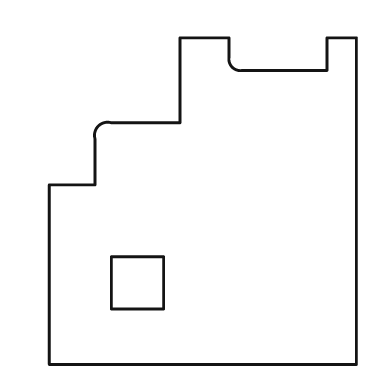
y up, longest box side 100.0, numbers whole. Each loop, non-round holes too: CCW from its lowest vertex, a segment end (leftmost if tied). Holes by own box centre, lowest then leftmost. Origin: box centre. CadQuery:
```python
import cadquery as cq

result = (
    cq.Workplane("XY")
    .moveTo(-47.0, -50.0)
    .lineTo(47.0, -50.0)
    .lineTo(47.0, 50.0)
    .lineTo(38.0, 50.0)
    .lineTo(38.0, 40.0)
    .lineTo(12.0, 40.0)
    .threePointArc((9.0, 41.0), (8.0, 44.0))
    .lineTo(8.0, 50.0)
    .lineTo(-7.0, 50.0)
    .lineTo(-7.0, 24.0)
    .lineTo(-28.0, 24.0)
    .threePointArc((-32.0, 23.0), (-33.0, 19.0))
    .lineTo(-33.0, 5.0)
    .lineTo(-47.0, 5.0)
    .close()
    .moveTo(-28.0, -33.0)
    .lineTo(-12.0, -33.0)
    .lineTo(-12.0, -17.0)
    .lineTo(-28.0, -17.0)
    .close()
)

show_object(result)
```